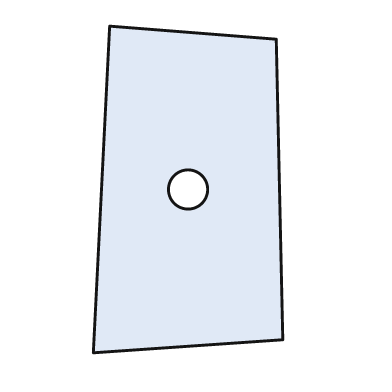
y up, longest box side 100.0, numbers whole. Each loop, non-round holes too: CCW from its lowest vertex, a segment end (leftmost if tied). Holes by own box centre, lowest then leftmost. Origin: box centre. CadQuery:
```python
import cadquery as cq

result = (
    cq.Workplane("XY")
    .moveTo(-29.0, -50.0)
    .lineTo(29.0, -46.0)
    .lineTo(27.0, 46.0)
    .lineTo(-24.0, 50.0)
    .close()
    .moveTo(0.0, 0.0)
    .circle(6.0)
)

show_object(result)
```